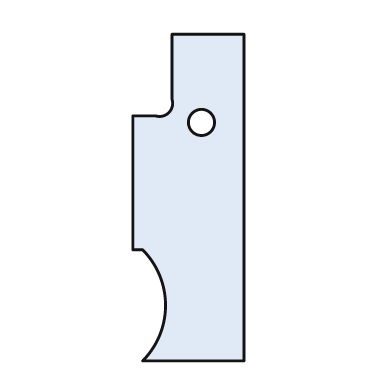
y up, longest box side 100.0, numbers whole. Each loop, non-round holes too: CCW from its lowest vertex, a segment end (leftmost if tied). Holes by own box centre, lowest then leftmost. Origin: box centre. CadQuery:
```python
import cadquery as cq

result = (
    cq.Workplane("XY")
    .moveTo(-14.0, -50.0)
    .lineTo(17.0, -50.0)
    .lineTo(17.0, 50.0)
    .lineTo(-5.0, 50.0)
    .lineTo(-5.0, 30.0)
    .threePointArc((-6.0, 26.0), (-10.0, 25.0))
    .lineTo(-17.0, 25.0)
    .lineTo(-17.0, -16.0)
    .lineTo(-14.0, -16.0)
    .threePointArc((-7.0, -33.0), (-14.0, -50.0))
    .close()
    .moveTo(4.0, 23.0)
    .circle(4.0)
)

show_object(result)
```